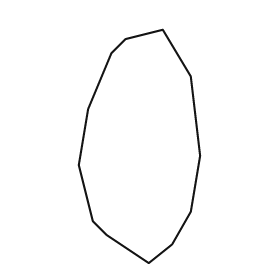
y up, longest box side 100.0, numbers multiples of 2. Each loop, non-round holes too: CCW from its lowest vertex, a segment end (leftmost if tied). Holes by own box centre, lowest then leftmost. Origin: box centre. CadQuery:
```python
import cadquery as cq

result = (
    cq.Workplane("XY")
    .moveTo(4.0, -50.0)
    .lineTo(14.0, -42.0)
    .lineTo(22.0, -28.0)
    .lineTo(26.0, -4.0)
    .lineTo(22.0, 30.0)
    .lineTo(10.0, 50.0)
    .lineTo(-6.0, 46.0)
    .lineTo(-12.0, 40.0)
    .lineTo(-22.0, 16.0)
    .lineTo(-26.0, -8.0)
    .lineTo(-20.0, -32.0)
    .lineTo(-14.0, -38.0)
    .close()
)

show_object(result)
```